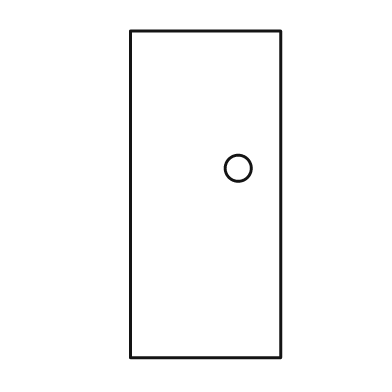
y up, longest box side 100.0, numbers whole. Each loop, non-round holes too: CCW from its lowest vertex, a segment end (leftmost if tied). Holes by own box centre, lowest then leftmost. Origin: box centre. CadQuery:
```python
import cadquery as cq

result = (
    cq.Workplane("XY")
    .moveTo(-23.0, -50.0)
    .lineTo(23.0, -50.0)
    .lineTo(23.0, 50.0)
    .lineTo(-23.0, 50.0)
    .close()
    .moveTo(10.0, 8.0)
    .circle(4.0)
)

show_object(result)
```